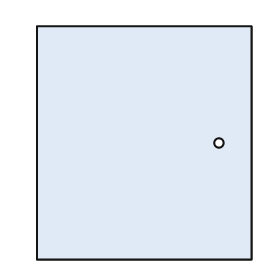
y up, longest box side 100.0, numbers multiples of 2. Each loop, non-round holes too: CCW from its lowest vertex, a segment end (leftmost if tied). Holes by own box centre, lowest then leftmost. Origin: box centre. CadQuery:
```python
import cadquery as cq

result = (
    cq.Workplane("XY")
    .moveTo(-46.0, -50.0)
    .lineTo(46.0, -50.0)
    .lineTo(46.0, 50.0)
    .lineTo(-46.0, 50.0)
    .close()
    .moveTo(32.0, 0.0)
    .circle(2.0)
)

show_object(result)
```